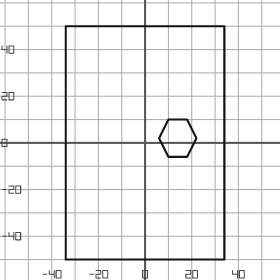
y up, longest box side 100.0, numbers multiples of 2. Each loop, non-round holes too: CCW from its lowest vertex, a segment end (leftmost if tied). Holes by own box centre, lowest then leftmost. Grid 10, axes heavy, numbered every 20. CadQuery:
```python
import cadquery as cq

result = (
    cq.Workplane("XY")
    .moveTo(-34.0, -50.0)
    .lineTo(34.0, -50.0)
    .lineTo(34.0, 50.0)
    .lineTo(-34.0, 50.0)
    .close()
    .moveTo(10.0, -6.0)
    .lineTo(18.0, -6.0)
    .lineTo(22.0, 2.0)
    .lineTo(18.0, 10.0)
    .lineTo(10.0, 10.0)
    .lineTo(6.0, 2.0)
    .close()
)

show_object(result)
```